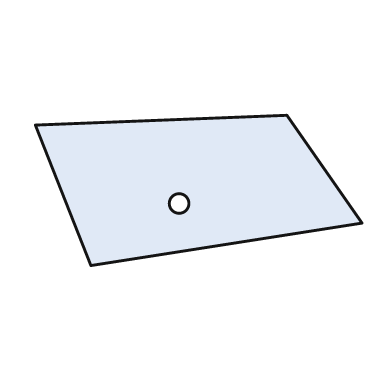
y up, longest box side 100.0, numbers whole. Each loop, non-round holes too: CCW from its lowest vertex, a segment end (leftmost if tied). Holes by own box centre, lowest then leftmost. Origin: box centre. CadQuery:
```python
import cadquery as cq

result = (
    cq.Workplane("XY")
    .moveTo(-33.0, -23.0)
    .lineTo(50.0, -10.0)
    .lineTo(27.0, 23.0)
    .lineTo(-50.0, 20.0)
    .close()
    .moveTo(-6.0, -4.0)
    .circle(3.0)
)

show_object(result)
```